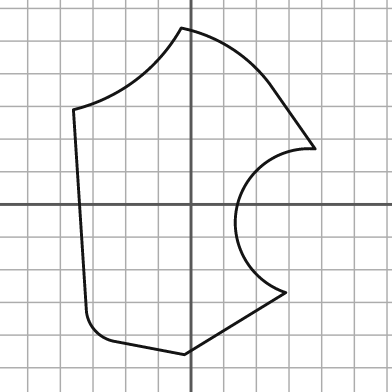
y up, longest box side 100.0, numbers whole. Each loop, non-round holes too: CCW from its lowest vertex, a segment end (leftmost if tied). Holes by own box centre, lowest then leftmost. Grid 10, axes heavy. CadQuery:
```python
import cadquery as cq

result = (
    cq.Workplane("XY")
    .moveTo(-2.0, -46.0)
    .lineTo(29.0, -27.0)
    .threePointArc((14.0, -1.0), (38.0, 17.0))
    .lineTo(24.0, 37.0)
    .threePointArc((12.0, 48.0), (-3.0, 54.0))
    .threePointArc((-17.0, 38.0), (-36.0, 29.0))
    .lineTo(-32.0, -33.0)
    .threePointArc((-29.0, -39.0), (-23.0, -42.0))
    .close()
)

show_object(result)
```